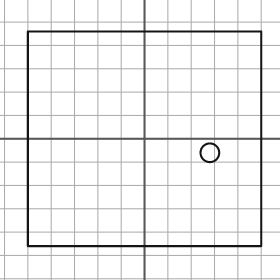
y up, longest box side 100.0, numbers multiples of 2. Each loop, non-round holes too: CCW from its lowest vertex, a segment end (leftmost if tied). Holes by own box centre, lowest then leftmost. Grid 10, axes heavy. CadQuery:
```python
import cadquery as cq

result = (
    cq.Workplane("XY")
    .moveTo(-50.0, -46.0)
    .lineTo(50.0, -46.0)
    .lineTo(50.0, 46.0)
    .lineTo(-50.0, 46.0)
    .close()
    .moveTo(28.0, -6.0)
    .circle(4.0)
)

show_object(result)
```